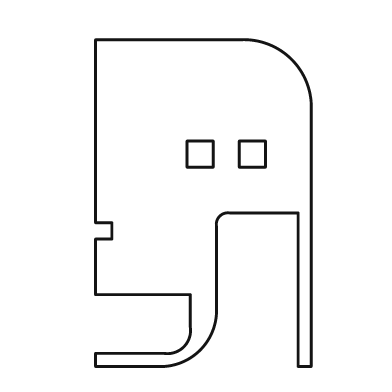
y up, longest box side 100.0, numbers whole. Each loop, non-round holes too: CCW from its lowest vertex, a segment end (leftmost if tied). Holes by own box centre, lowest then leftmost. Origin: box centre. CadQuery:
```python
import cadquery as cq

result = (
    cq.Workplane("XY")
    .moveTo(-33.0, -50.0)
    .lineTo(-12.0, -50.0)
    .threePointArc((-1.0, -45.0), (4.0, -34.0))
    .lineTo(4.0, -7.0)
    .threePointArc((5.0, -4.0), (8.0, -3.0))
    .lineTo(29.0, -3.0)
    .lineTo(29.0, -50.0)
    .lineTo(33.0, -50.0)
    .lineTo(33.0, 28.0)
    .threePointArc((27.0, 44.0), (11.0, 50.0))
    .lineTo(-33.0, 50.0)
    .lineTo(-33.0, -6.0)
    .lineTo(-28.0, -6.0)
    .lineTo(-28.0, -11.0)
    .lineTo(-33.0, -11.0)
    .lineTo(-33.0, -28.0)
    .lineTo(-4.0, -28.0)
    .lineTo(-4.0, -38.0)
    .threePointArc((-6.0, -44.0), (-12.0, -46.0))
    .lineTo(-33.0, -46.0)
    .close()
    .moveTo(-5.0, 11.0)
    .lineTo(3.0, 11.0)
    .lineTo(3.0, 19.0)
    .lineTo(-5.0, 19.0)
    .close()
    .moveTo(11.0, 11.0)
    .lineTo(19.0, 11.0)
    .lineTo(19.0, 19.0)
    .lineTo(11.0, 19.0)
    .close()
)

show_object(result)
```